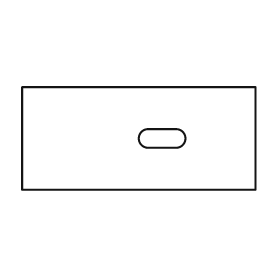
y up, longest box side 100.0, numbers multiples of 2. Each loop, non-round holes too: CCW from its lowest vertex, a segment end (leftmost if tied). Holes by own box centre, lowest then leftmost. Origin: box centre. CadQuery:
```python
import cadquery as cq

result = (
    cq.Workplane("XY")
    .moveTo(-50.0, -22.0)
    .lineTo(50.0, -22.0)
    .lineTo(50.0, 22.0)
    .lineTo(-50.0, 22.0)
    .close()
    .moveTo(4.0, -4.0)
    .lineTo(16.0, -4.0)
    .threePointArc((20.0, 0.0), (16.0, 4.0))
    .lineTo(4.0, 4.0)
    .threePointArc((0.0, 0.0), (4.0, -4.0))
    .close()
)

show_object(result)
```